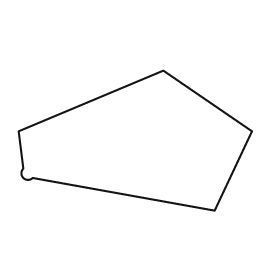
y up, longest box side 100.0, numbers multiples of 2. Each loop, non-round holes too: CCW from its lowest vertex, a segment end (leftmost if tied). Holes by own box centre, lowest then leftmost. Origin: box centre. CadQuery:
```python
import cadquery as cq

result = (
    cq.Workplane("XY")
    .moveTo(34.0, -30.0)
    .lineTo(50.0, 4.0)
    .lineTo(12.0, 30.0)
    .lineTo(-50.0, 4.0)
    .lineTo(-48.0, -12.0)
    .threePointArc((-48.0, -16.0), (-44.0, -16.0))
    .close()
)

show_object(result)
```